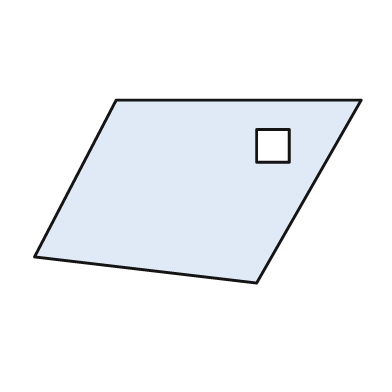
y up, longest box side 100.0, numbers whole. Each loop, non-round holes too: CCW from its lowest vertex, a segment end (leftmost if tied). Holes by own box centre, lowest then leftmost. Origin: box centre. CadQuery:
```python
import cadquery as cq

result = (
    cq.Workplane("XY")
    .moveTo(18.0, -28.0)
    .lineTo(50.0, 28.0)
    .lineTo(-25.0, 28.0)
    .lineTo(-50.0, -20.0)
    .close()
    .moveTo(18.0, 9.0)
    .lineTo(28.0, 9.0)
    .lineTo(28.0, 19.0)
    .lineTo(18.0, 19.0)
    .close()
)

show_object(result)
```